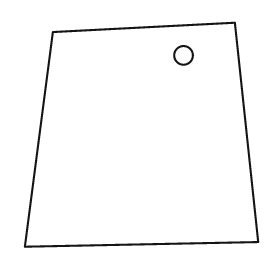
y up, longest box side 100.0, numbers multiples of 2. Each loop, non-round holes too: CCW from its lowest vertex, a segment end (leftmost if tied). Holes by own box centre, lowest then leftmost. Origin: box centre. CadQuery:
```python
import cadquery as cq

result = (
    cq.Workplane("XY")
    .moveTo(-50.0, -48.0)
    .lineTo(50.0, -46.0)
    .lineTo(40.0, 48.0)
    .lineTo(-38.0, 44.0)
    .close()
    .moveTo(18.0, 34.0)
    .circle(4.0)
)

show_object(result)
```